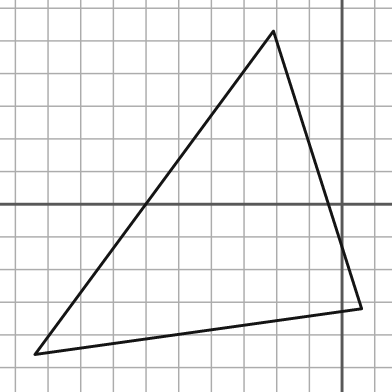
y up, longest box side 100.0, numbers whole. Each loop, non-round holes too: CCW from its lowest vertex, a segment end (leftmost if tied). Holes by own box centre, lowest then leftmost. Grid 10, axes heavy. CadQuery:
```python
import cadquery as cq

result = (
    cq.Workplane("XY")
    .moveTo(-94.0, -46.0)
    .lineTo(6.0, -32.0)
    .lineTo(-21.0, 53.0)
    .close()
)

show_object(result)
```